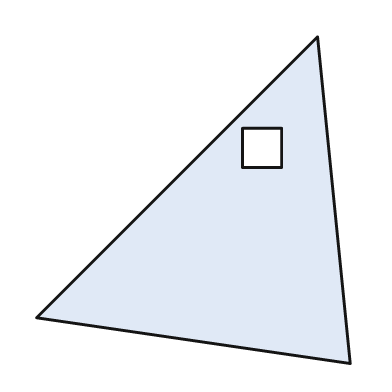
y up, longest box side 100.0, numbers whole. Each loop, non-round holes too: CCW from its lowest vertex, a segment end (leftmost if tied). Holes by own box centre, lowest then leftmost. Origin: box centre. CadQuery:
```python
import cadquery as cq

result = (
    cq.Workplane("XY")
    .moveTo(48.0, -50.0)
    .lineTo(38.0, 50.0)
    .lineTo(-48.0, -36.0)
    .close()
    .moveTo(15.0, 10.0)
    .lineTo(27.0, 10.0)
    .lineTo(27.0, 22.0)
    .lineTo(15.0, 22.0)
    .close()
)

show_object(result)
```